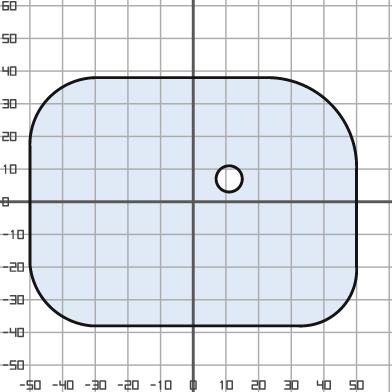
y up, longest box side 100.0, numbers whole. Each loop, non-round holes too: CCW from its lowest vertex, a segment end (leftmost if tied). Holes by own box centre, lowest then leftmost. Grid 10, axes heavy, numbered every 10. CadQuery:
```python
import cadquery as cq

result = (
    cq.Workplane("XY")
    .moveTo(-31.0, -38.0)
    .lineTo(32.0, -38.0)
    .threePointArc((45.0, -33.0), (50.0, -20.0))
    .lineTo(50.0, 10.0)
    .threePointArc((42.0, 30.0), (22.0, 38.0))
    .lineTo(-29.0, 38.0)
    .threePointArc((-44.0, 32.0), (-50.0, 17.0))
    .lineTo(-50.0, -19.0)
    .threePointArc((-44.0, -32.0), (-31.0, -38.0))
    .close()
    .moveTo(11.0, 7.0)
    .circle(4.0)
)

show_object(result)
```